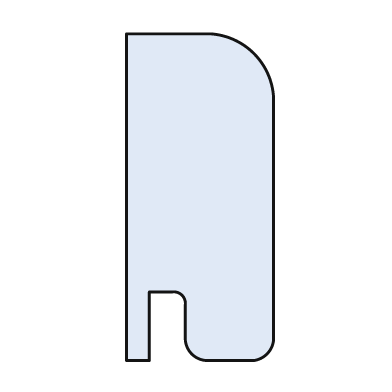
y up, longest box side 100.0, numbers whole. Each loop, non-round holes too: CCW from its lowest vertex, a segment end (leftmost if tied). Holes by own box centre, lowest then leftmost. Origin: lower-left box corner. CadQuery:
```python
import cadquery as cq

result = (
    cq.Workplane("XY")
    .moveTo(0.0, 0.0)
    .lineTo(7.0, 0.0)
    .lineTo(7.0, 21.0)
    .lineTo(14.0, 21.0)
    .threePointArc((17.0, 20.0), (18.0, 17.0))
    .lineTo(18.0, 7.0)
    .threePointArc((20.0, 2.0), (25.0, 0.0))
    .lineTo(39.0, 0.0)
    .threePointArc((43.0, 2.0), (45.0, 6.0))
    .lineTo(45.0, 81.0)
    .threePointArc((39.0, 94.0), (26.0, 100.0))
    .lineTo(0.0, 100.0)
    .close()
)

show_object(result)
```